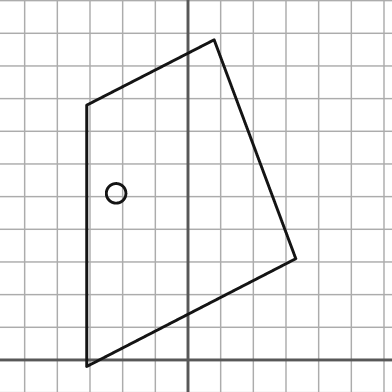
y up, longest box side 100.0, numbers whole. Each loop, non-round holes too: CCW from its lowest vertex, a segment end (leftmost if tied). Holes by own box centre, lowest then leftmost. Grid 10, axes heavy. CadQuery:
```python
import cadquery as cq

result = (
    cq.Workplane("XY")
    .moveTo(-31.0, -2.0)
    .lineTo(33.0, 31.0)
    .lineTo(8.0, 98.0)
    .lineTo(-31.0, 78.0)
    .close()
    .moveTo(-22.0, 51.0)
    .circle(3.0)
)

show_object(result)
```